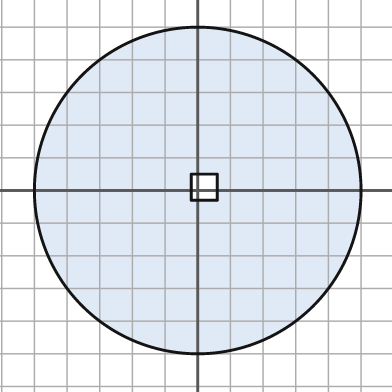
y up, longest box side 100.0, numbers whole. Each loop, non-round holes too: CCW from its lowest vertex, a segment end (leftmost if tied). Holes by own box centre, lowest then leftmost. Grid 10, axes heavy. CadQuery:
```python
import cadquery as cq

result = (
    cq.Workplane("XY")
    .moveTo(0.0, 0.0)
    .circle(50.0)
    .moveTo(-2.0, -3.0)
    .lineTo(6.0, -3.0)
    .lineTo(6.0, 5.0)
    .lineTo(-2.0, 5.0)
    .close()
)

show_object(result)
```